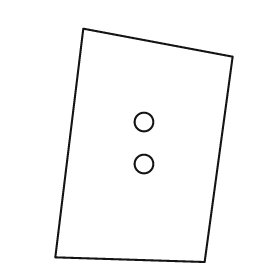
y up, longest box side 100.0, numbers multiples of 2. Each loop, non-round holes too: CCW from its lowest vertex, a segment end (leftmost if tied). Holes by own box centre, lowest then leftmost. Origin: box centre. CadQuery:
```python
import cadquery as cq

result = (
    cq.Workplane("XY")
    .moveTo(26.0, -50.0)
    .lineTo(38.0, 38.0)
    .lineTo(-26.0, 50.0)
    .lineTo(-38.0, -48.0)
    .close()
    .moveTo(0.0, -8.0)
    .circle(4.0)
    .moveTo(0.0, 10.0)
    .circle(4.0)
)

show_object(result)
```